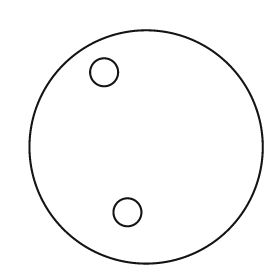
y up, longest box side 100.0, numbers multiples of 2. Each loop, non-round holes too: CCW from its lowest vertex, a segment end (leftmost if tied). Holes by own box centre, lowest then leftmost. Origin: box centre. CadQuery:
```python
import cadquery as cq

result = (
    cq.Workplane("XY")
    .moveTo(0.0, 0.0)
    .circle(50.0)
    .moveTo(-8.0, -28.0)
    .circle(6.0)
    .moveTo(-18.0, 32.0)
    .circle(6.0)
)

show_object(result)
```